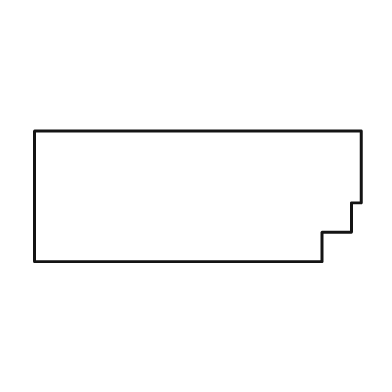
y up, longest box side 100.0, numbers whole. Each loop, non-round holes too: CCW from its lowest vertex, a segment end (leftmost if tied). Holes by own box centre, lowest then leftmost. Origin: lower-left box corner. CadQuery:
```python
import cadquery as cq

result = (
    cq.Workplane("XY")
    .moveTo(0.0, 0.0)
    .lineTo(88.0, 0.0)
    .lineTo(88.0, 9.0)
    .lineTo(97.0, 9.0)
    .lineTo(97.0, 18.0)
    .lineTo(100.0, 18.0)
    .lineTo(100.0, 40.0)
    .lineTo(0.0, 40.0)
    .close()
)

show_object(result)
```